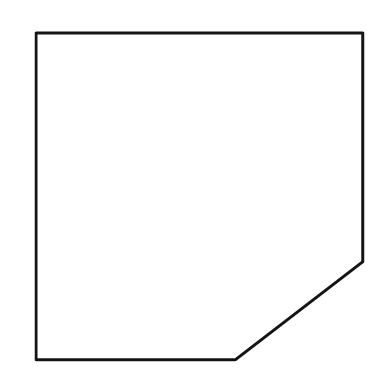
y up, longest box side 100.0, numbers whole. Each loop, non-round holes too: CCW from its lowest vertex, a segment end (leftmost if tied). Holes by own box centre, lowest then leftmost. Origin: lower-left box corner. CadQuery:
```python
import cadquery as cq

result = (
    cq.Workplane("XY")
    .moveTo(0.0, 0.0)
    .lineTo(61.0, 0.0)
    .lineTo(100.0, 30.0)
    .lineTo(100.0, 100.0)
    .lineTo(0.0, 100.0)
    .close()
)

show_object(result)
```